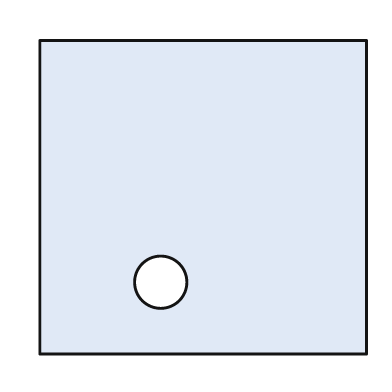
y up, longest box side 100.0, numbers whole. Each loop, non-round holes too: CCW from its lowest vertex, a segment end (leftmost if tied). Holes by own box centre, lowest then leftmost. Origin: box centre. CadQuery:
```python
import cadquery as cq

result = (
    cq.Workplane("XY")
    .moveTo(-50.0, -48.0)
    .lineTo(50.0, -48.0)
    .lineTo(50.0, 48.0)
    .lineTo(-50.0, 48.0)
    .close()
    .moveTo(-13.0, -26.0)
    .circle(8.0)
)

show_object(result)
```